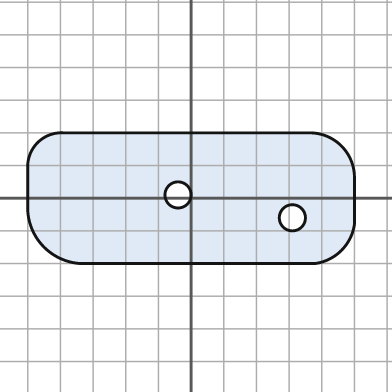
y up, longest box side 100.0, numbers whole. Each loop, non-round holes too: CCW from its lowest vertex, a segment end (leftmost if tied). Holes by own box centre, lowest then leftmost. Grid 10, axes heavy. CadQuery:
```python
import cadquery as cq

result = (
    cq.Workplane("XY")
    .moveTo(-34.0, -20.0)
    .lineTo(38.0, -20.0)
    .threePointArc((46.0, -16.0), (50.0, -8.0))
    .lineTo(50.0, 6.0)
    .threePointArc((46.0, 16.0), (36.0, 20.0))
    .lineTo(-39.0, 20.0)
    .threePointArc((-47.0, 17.0), (-50.0, 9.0))
    .lineTo(-50.0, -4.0)
    .threePointArc((-45.0, -15.0), (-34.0, -20.0))
    .close()
    .moveTo(31.0, -6.0)
    .circle(4.0)
    .moveTo(-4.0, 1.0)
    .circle(4.0)
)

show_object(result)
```